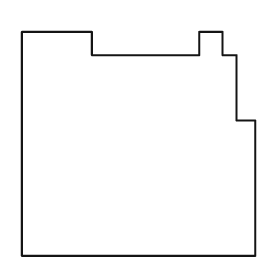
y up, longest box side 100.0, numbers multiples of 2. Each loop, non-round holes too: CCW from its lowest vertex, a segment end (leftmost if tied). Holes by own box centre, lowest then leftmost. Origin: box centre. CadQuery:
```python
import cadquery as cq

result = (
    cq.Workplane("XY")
    .moveTo(-50.0, -48.0)
    .lineTo(50.0, -48.0)
    .lineTo(50.0, 10.0)
    .lineTo(42.0, 10.0)
    .lineTo(42.0, 38.0)
    .lineTo(36.0, 38.0)
    .lineTo(36.0, 48.0)
    .lineTo(26.0, 48.0)
    .lineTo(26.0, 38.0)
    .lineTo(-20.0, 38.0)
    .lineTo(-20.0, 48.0)
    .lineTo(-50.0, 48.0)
    .close()
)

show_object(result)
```